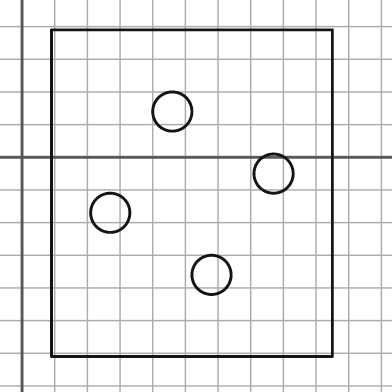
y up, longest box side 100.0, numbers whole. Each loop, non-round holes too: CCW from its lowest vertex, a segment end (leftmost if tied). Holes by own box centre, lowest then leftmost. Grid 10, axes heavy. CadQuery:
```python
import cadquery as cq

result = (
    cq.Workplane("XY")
    .moveTo(9.0, -61.0)
    .lineTo(95.0, -61.0)
    .lineTo(95.0, 39.0)
    .lineTo(9.0, 39.0)
    .close()
    .moveTo(58.0, -36.0)
    .circle(6.0)
    .moveTo(27.0, -17.0)
    .circle(6.0)
    .moveTo(77.0, -5.0)
    .circle(6.0)
    .moveTo(46.0, 14.0)
    .circle(6.0)
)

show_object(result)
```